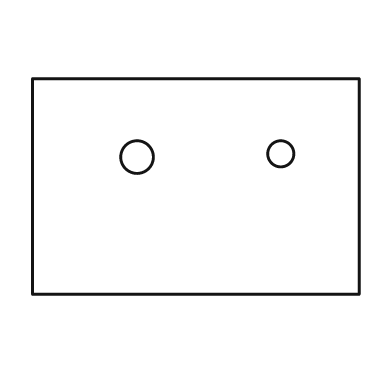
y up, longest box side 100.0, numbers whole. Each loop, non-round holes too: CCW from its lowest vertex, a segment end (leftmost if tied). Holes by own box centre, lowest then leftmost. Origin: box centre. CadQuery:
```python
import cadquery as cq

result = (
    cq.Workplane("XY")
    .moveTo(-50.0, -33.0)
    .lineTo(50.0, -33.0)
    .lineTo(50.0, 33.0)
    .lineTo(-50.0, 33.0)
    .close()
    .moveTo(-18.0, 9.0)
    .circle(5.0)
    .moveTo(26.0, 10.0)
    .circle(4.0)
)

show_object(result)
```